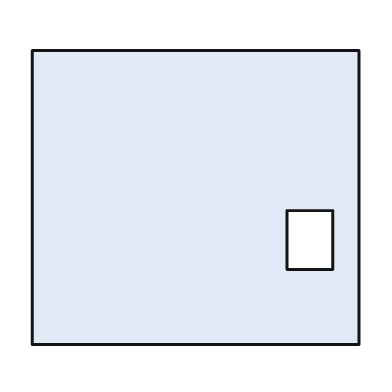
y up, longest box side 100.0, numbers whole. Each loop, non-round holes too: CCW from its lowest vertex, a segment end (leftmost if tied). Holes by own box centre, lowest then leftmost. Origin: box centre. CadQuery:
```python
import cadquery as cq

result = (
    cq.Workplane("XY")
    .moveTo(-50.0, -45.0)
    .lineTo(50.0, -45.0)
    .lineTo(50.0, 45.0)
    .lineTo(-50.0, 45.0)
    .close()
    .moveTo(28.0, -22.0)
    .lineTo(42.0, -22.0)
    .lineTo(42.0, -4.0)
    .lineTo(28.0, -4.0)
    .close()
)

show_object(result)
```